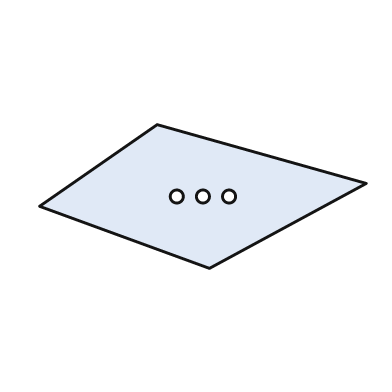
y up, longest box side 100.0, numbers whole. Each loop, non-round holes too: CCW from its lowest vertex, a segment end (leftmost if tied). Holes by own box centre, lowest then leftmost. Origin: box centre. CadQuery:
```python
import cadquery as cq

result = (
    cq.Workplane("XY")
    .moveTo(2.0, -22.0)
    .lineTo(50.0, 4.0)
    .lineTo(-14.0, 22.0)
    .lineTo(-50.0, -3.0)
    .close()
    .moveTo(-8.0, 0.0)
    .circle(2.0)
    .moveTo(0.0, 0.0)
    .circle(2.0)
    .moveTo(8.0, 0.0)
    .circle(2.0)
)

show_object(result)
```